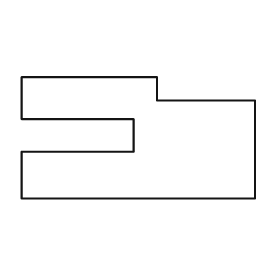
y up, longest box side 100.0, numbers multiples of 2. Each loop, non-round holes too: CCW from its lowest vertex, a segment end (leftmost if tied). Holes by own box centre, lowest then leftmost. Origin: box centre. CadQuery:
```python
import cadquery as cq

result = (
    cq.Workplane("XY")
    .moveTo(-50.0, -26.0)
    .lineTo(50.0, -26.0)
    .lineTo(50.0, 16.0)
    .lineTo(8.0, 16.0)
    .lineTo(8.0, 26.0)
    .lineTo(-50.0, 26.0)
    .lineTo(-50.0, 8.0)
    .lineTo(-2.0, 8.0)
    .lineTo(-2.0, -6.0)
    .lineTo(-50.0, -6.0)
    .close()
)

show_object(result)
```